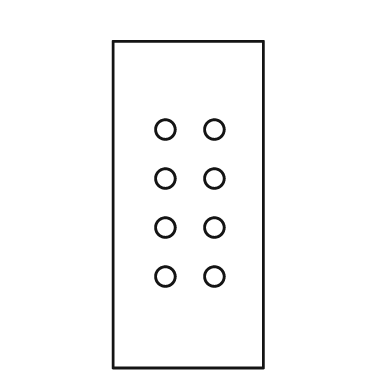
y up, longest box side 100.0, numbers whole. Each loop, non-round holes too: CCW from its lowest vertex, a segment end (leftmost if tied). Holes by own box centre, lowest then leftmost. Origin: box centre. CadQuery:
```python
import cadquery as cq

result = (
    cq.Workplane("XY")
    .moveTo(-23.0, -50.0)
    .lineTo(23.0, -50.0)
    .lineTo(23.0, 50.0)
    .lineTo(-23.0, 50.0)
    .close()
    .moveTo(-7.0, -22.0)
    .circle(3.0)
    .moveTo(8.0, -22.0)
    .circle(3.0)
    .moveTo(-7.0, -7.0)
    .circle(3.0)
    .moveTo(8.0, -7.0)
    .circle(3.0)
    .moveTo(-7.0, 8.0)
    .circle(3.0)
    .moveTo(8.0, 8.0)
    .circle(3.0)
    .moveTo(-7.0, 23.0)
    .circle(3.0)
    .moveTo(8.0, 23.0)
    .circle(3.0)
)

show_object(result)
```